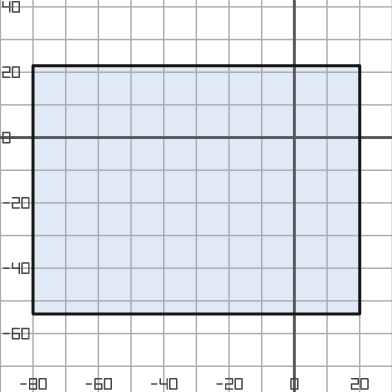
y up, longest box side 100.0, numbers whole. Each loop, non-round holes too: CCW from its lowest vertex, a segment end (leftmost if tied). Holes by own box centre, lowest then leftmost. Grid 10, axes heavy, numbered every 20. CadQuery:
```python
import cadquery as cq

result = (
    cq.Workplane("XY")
    .moveTo(-80.0, -54.0)
    .lineTo(20.0, -54.0)
    .lineTo(20.0, 22.0)
    .lineTo(-80.0, 22.0)
    .close()
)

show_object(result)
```